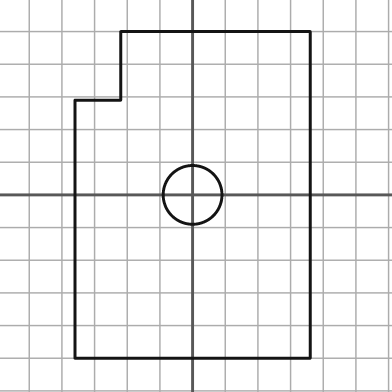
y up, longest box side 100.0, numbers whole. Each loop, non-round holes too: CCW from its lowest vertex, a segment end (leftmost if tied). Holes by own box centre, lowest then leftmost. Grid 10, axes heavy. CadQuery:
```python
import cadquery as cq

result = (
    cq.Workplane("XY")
    .moveTo(-36.0, -50.0)
    .lineTo(36.0, -50.0)
    .lineTo(36.0, 50.0)
    .lineTo(-22.0, 50.0)
    .lineTo(-22.0, 29.0)
    .lineTo(-36.0, 29.0)
    .close()
    .moveTo(0.0, 0.0)
    .circle(9.0)
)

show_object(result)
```